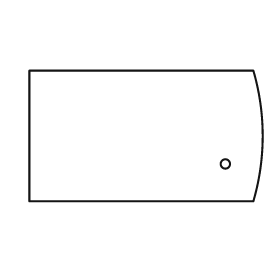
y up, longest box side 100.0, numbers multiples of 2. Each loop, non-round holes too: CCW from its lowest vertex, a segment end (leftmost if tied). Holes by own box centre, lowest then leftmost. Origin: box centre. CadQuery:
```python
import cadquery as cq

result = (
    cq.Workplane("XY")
    .moveTo(-50.0, -28.0)
    .lineTo(46.0, -28.0)
    .threePointArc((50.0, 0.0), (46.0, 28.0))
    .lineTo(-50.0, 28.0)
    .close()
    .moveTo(34.0, -12.0)
    .circle(2.0)
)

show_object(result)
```